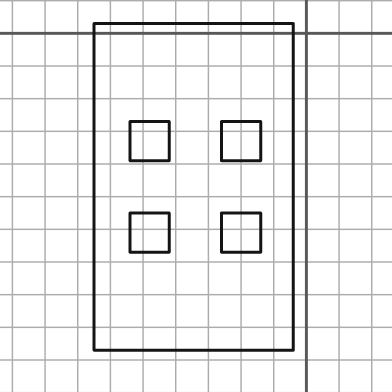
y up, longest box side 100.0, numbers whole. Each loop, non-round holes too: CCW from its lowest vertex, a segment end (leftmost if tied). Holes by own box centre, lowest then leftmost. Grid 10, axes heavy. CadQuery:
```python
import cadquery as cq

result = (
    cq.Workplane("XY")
    .moveTo(-65.0, -97.0)
    .lineTo(-4.0, -97.0)
    .lineTo(-4.0, 3.0)
    .lineTo(-65.0, 3.0)
    .close()
    .moveTo(-54.0, -67.0)
    .lineTo(-42.0, -67.0)
    .lineTo(-42.0, -55.0)
    .lineTo(-54.0, -55.0)
    .close()
    .moveTo(-26.0, -67.0)
    .lineTo(-14.0, -67.0)
    .lineTo(-14.0, -55.0)
    .lineTo(-26.0, -55.0)
    .close()
    .moveTo(-54.0, -39.0)
    .lineTo(-42.0, -39.0)
    .lineTo(-42.0, -27.0)
    .lineTo(-54.0, -27.0)
    .close()
    .moveTo(-26.0, -39.0)
    .lineTo(-14.0, -39.0)
    .lineTo(-14.0, -27.0)
    .lineTo(-26.0, -27.0)
    .close()
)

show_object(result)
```